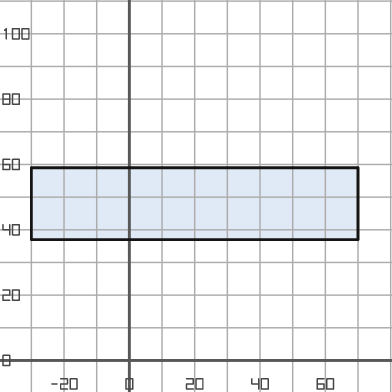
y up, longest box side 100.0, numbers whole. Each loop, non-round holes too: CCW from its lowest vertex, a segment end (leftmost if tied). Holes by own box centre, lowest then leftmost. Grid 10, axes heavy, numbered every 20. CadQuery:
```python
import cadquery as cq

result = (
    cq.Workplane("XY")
    .moveTo(-30.0, 37.0)
    .lineTo(70.0, 37.0)
    .lineTo(70.0, 59.0)
    .lineTo(-30.0, 59.0)
    .close()
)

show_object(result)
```